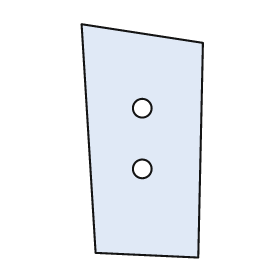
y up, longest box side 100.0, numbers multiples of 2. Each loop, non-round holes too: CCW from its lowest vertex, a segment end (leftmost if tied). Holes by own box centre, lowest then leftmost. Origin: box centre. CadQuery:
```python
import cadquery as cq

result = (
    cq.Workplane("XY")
    .moveTo(24.0, -50.0)
    .lineTo(26.0, 42.0)
    .lineTo(-26.0, 50.0)
    .lineTo(-20.0, -48.0)
    .close()
    .moveTo(0.0, -12.0)
    .circle(4.0)
    .moveTo(0.0, 14.0)
    .circle(4.0)
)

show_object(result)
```